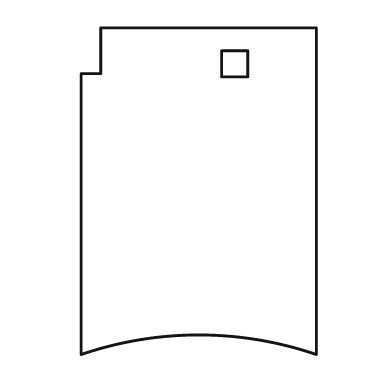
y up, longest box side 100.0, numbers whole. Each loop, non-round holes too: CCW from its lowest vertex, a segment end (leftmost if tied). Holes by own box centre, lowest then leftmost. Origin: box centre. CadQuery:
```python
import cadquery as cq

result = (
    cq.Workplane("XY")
    .moveTo(-36.0, -50.0)
    .threePointArc((0.0, -44.0), (36.0, -50.0))
    .lineTo(36.0, 50.0)
    .lineTo(-30.0, 50.0)
    .lineTo(-30.0, 36.0)
    .lineTo(-36.0, 36.0)
    .close()
    .moveTo(7.0, 35.0)
    .lineTo(15.0, 35.0)
    .lineTo(15.0, 43.0)
    .lineTo(7.0, 43.0)
    .close()
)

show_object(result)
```